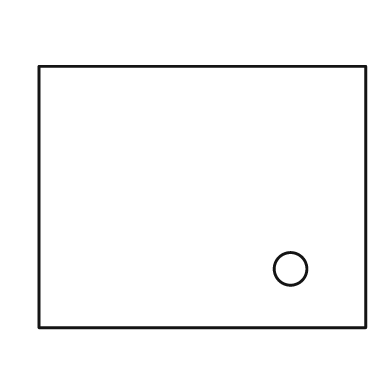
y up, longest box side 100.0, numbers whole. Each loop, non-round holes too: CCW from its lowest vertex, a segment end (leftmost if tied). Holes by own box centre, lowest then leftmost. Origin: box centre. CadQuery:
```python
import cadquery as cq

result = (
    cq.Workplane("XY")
    .moveTo(-50.0, -40.0)
    .lineTo(50.0, -40.0)
    .lineTo(50.0, 40.0)
    .lineTo(-50.0, 40.0)
    .close()
    .moveTo(27.0, -22.0)
    .circle(5.0)
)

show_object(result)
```